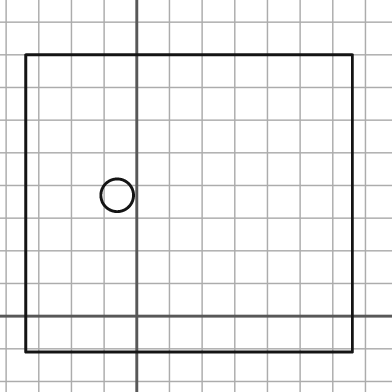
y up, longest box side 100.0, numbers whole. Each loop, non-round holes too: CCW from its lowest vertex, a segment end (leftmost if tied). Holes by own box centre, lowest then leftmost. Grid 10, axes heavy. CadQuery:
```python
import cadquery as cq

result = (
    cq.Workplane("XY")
    .moveTo(-34.0, -11.0)
    .lineTo(66.0, -11.0)
    .lineTo(66.0, 80.0)
    .lineTo(-34.0, 80.0)
    .close()
    .moveTo(-6.0, 37.0)
    .circle(5.0)
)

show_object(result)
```